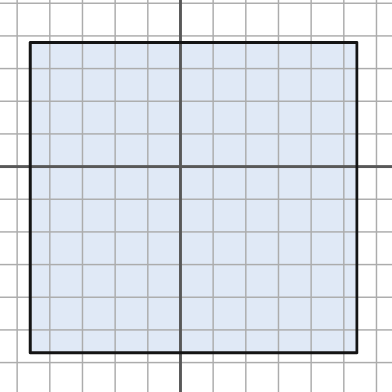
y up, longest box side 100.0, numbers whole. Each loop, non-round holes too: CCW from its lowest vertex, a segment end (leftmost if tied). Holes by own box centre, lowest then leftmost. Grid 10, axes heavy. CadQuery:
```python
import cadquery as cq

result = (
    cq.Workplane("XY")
    .moveTo(-46.0, -57.0)
    .lineTo(54.0, -57.0)
    .lineTo(54.0, 38.0)
    .lineTo(-46.0, 38.0)
    .close()
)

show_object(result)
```